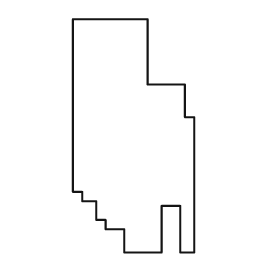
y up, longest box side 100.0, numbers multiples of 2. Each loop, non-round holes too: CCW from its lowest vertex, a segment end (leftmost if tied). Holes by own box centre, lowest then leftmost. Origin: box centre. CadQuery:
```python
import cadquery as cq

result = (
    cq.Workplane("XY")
    .moveTo(-4.0, -50.0)
    .lineTo(12.0, -50.0)
    .lineTo(12.0, -30.0)
    .lineTo(20.0, -30.0)
    .lineTo(20.0, -50.0)
    .lineTo(26.0, -50.0)
    .lineTo(26.0, 8.0)
    .lineTo(22.0, 8.0)
    .lineTo(22.0, 22.0)
    .lineTo(6.0, 22.0)
    .lineTo(6.0, 50.0)
    .lineTo(-26.0, 50.0)
    .lineTo(-26.0, -24.0)
    .lineTo(-22.0, -24.0)
    .lineTo(-22.0, -28.0)
    .lineTo(-16.0, -28.0)
    .lineTo(-16.0, -36.0)
    .lineTo(-12.0, -36.0)
    .lineTo(-12.0, -40.0)
    .lineTo(-4.0, -40.0)
    .close()
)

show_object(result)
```